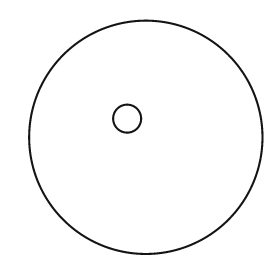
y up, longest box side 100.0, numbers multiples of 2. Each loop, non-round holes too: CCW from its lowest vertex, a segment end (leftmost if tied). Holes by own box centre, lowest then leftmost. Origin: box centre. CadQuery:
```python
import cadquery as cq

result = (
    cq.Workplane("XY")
    .moveTo(0.0, 0.0)
    .circle(50.0)
    .moveTo(-8.0, 8.0)
    .circle(6.0)
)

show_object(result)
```